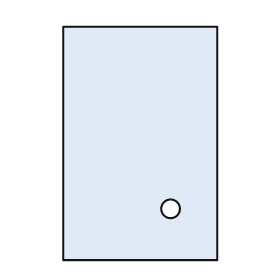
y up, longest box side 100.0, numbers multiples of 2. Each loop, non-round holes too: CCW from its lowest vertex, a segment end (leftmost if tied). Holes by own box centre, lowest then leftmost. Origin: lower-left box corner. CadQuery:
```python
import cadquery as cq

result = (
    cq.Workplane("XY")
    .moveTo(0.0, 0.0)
    .lineTo(66.0, 0.0)
    .lineTo(66.0, 100.0)
    .lineTo(0.0, 100.0)
    .close()
    .moveTo(46.0, 22.0)
    .circle(4.0)
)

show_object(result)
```